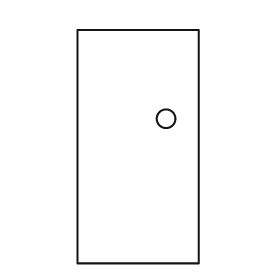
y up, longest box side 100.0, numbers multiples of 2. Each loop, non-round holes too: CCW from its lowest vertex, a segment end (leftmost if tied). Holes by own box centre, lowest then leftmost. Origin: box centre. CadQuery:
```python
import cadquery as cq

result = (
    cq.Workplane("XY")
    .moveTo(-26.0, -50.0)
    .lineTo(26.0, -50.0)
    .lineTo(26.0, 50.0)
    .lineTo(-26.0, 50.0)
    .close()
    .moveTo(12.0, 12.0)
    .circle(4.0)
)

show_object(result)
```